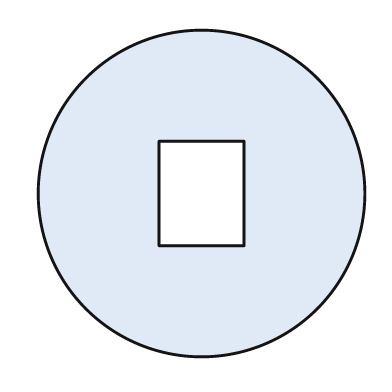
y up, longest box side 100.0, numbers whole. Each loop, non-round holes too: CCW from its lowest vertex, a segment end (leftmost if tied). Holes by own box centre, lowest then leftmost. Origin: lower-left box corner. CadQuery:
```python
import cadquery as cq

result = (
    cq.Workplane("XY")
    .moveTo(50.0, 50.0)
    .circle(50.0)
    .moveTo(37.0, 34.0)
    .lineTo(63.0, 34.0)
    .lineTo(63.0, 66.0)
    .lineTo(37.0, 66.0)
    .close()
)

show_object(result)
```